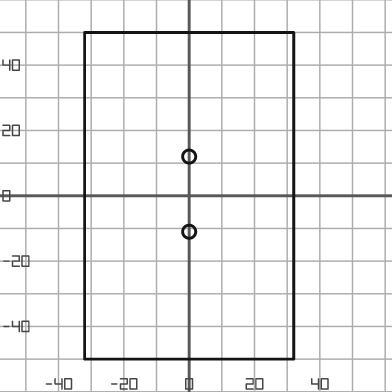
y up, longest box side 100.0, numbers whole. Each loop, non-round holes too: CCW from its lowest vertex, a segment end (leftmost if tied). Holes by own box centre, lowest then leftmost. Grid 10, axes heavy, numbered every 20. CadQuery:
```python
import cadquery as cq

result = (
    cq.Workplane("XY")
    .moveTo(-32.0, -50.0)
    .lineTo(32.0, -50.0)
    .lineTo(32.0, 50.0)
    .lineTo(-32.0, 50.0)
    .close()
    .moveTo(0.0, -11.0)
    .circle(2.0)
    .moveTo(0.0, 12.0)
    .circle(2.0)
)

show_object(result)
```